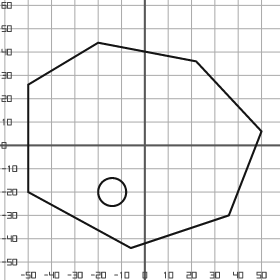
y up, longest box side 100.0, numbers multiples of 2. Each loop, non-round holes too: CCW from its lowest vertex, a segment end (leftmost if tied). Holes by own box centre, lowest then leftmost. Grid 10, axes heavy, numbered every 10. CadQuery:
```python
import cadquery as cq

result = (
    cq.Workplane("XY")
    .moveTo(-6.0, -44.0)
    .lineTo(36.0, -30.0)
    .lineTo(50.0, 6.0)
    .lineTo(22.0, 36.0)
    .lineTo(-20.0, 44.0)
    .lineTo(-50.0, 26.0)
    .lineTo(-50.0, -20.0)
    .close()
    .moveTo(-14.0, -20.0)
    .circle(6.0)
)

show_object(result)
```